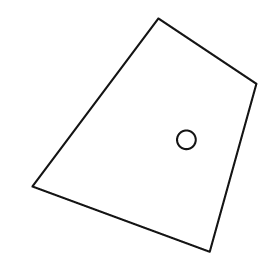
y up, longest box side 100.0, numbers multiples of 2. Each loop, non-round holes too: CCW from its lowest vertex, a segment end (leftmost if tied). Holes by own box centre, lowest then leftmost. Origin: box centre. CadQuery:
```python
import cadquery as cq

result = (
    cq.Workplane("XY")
    .moveTo(28.0, -50.0)
    .lineTo(48.0, 22.0)
    .lineTo(6.0, 50.0)
    .lineTo(-48.0, -22.0)
    .close()
    .moveTo(18.0, -2.0)
    .circle(4.0)
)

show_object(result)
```